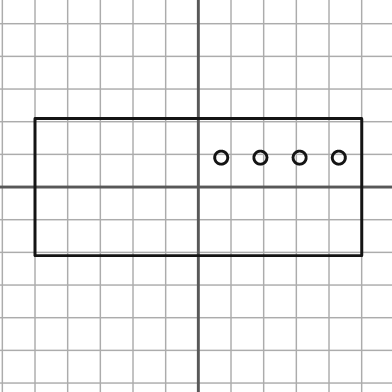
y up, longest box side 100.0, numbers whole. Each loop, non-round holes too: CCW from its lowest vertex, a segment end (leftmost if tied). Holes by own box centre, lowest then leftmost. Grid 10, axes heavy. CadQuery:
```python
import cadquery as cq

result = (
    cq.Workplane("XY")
    .moveTo(-50.0, -21.0)
    .lineTo(50.0, -21.0)
    .lineTo(50.0, 21.0)
    .lineTo(-50.0, 21.0)
    .close()
    .moveTo(7.0, 9.0)
    .circle(2.0)
    .moveTo(19.0, 9.0)
    .circle(2.0)
    .moveTo(31.0, 9.0)
    .circle(2.0)
    .moveTo(43.0, 9.0)
    .circle(2.0)
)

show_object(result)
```